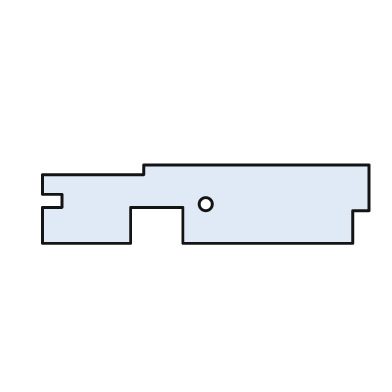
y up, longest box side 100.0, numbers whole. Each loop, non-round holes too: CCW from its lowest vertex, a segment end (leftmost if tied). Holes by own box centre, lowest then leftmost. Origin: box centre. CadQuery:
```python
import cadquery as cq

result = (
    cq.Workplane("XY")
    .moveTo(-50.0, -12.0)
    .lineTo(-23.0, -12.0)
    .lineTo(-23.0, -1.0)
    .lineTo(-7.0, -1.0)
    .lineTo(-7.0, -12.0)
    .lineTo(45.0, -12.0)
    .lineTo(45.0, -2.0)
    .lineTo(50.0, -2.0)
    .lineTo(50.0, 12.0)
    .lineTo(-19.0, 12.0)
    .lineTo(-19.0, 9.0)
    .lineTo(-50.0, 9.0)
    .lineTo(-50.0, 3.0)
    .lineTo(-44.0, 3.0)
    .lineTo(-44.0, -1.0)
    .lineTo(-50.0, -1.0)
    .close()
    .moveTo(0.0, 0.0)
    .circle(2.0)
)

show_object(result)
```